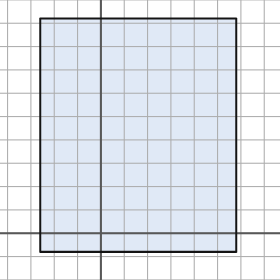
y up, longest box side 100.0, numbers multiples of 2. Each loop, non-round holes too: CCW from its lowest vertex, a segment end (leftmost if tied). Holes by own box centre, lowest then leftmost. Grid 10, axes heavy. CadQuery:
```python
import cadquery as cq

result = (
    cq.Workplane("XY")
    .moveTo(-26.0, -8.0)
    .lineTo(58.0, -8.0)
    .lineTo(58.0, 92.0)
    .lineTo(-26.0, 92.0)
    .close()
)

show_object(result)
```